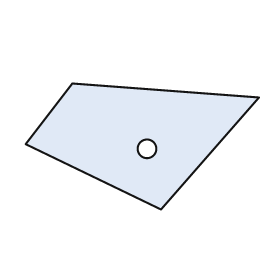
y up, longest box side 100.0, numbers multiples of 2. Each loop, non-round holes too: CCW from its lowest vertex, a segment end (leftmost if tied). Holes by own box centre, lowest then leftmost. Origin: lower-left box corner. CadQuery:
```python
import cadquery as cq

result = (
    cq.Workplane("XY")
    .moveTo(58.0, 0.0)
    .lineTo(100.0, 48.0)
    .lineTo(20.0, 54.0)
    .lineTo(0.0, 28.0)
    .close()
    .moveTo(52.0, 26.0)
    .circle(4.0)
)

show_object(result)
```